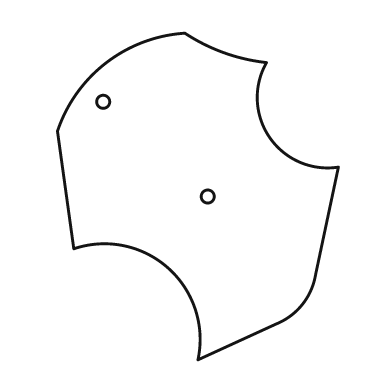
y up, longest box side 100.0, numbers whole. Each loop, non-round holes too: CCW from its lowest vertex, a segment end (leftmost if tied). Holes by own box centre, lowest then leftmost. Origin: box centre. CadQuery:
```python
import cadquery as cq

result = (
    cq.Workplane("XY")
    .moveTo(0.0, -50.0)
    .lineTo(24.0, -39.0)
    .threePointArc((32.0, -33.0), (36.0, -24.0))
    .lineTo(43.0, 9.0)
    .threePointArc((22.0, 18.0), (21.0, 41.0))
    .threePointArc((8.0, 44.0), (-4.0, 50.0))
    .threePointArc((-28.0, 41.0), (-43.0, 20.0))
    .lineTo(-38.0, -16.0)
    .threePointArc((-9.0, -22.0), (0.0, -50.0))
    .close()
    .moveTo(3.0, 0.0)
    .circle(2.0)
    .moveTo(-29.0, 29.0)
    .circle(2.0)
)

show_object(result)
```